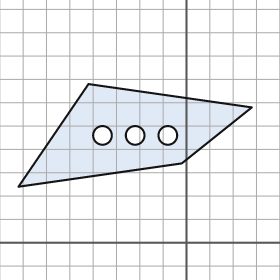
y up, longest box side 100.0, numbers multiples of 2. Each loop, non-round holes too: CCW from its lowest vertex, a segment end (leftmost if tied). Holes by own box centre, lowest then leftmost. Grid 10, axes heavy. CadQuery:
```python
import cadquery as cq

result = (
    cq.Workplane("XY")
    .moveTo(-72.0, 24.0)
    .lineTo(-2.0, 34.0)
    .lineTo(28.0, 58.0)
    .lineTo(-42.0, 68.0)
    .close()
    .moveTo(-36.0, 46.0)
    .circle(4.0)
    .moveTo(-22.0, 46.0)
    .circle(4.0)
    .moveTo(-8.0, 46.0)
    .circle(4.0)
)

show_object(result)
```